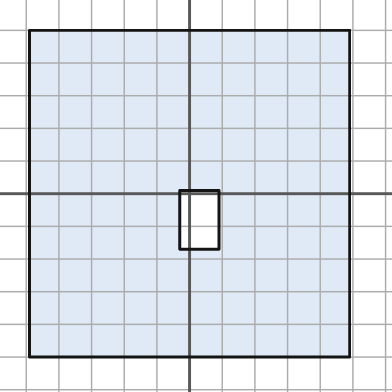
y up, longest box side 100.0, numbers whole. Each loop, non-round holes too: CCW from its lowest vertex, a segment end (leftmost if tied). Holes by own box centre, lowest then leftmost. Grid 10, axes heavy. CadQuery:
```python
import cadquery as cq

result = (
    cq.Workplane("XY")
    .moveTo(-49.0, -50.0)
    .lineTo(49.0, -50.0)
    .lineTo(49.0, 50.0)
    .lineTo(-49.0, 50.0)
    .close()
    .moveTo(-3.0, -17.0)
    .lineTo(9.0, -17.0)
    .lineTo(9.0, 1.0)
    .lineTo(-3.0, 1.0)
    .close()
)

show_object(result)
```